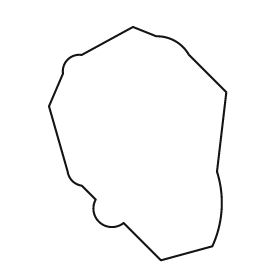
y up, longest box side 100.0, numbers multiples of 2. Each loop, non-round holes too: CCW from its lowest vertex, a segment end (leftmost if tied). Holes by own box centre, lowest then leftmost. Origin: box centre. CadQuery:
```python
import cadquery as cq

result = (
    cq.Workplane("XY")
    .moveTo(10.0, -50.0)
    .lineTo(32.0, -44.0)
    .threePointArc((36.0, -28.0), (34.0, -12.0))
    .lineTo(38.0, 22.0)
    .lineTo(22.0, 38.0)
    .threePointArc((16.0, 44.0), (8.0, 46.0))
    .lineTo(-2.0, 50.0)
    .lineTo(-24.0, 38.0)
    .threePointArc((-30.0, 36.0), (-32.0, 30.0))
    .lineTo(-38.0, 16.0)
    .lineTo(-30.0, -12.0)
    .threePointArc((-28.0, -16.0), (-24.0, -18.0))
    .lineTo(-18.0, -24.0)
    .threePointArc((-16.0, -34.0), (-6.0, -34.0))
    .close()
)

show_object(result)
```